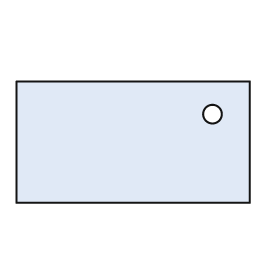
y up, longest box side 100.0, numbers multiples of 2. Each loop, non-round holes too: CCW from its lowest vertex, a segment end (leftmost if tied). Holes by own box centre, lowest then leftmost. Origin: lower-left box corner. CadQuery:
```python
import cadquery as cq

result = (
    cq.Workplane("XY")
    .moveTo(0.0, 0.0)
    .lineTo(100.0, 0.0)
    .lineTo(100.0, 52.0)
    .lineTo(0.0, 52.0)
    .close()
    .moveTo(84.0, 38.0)
    .circle(4.0)
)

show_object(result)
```